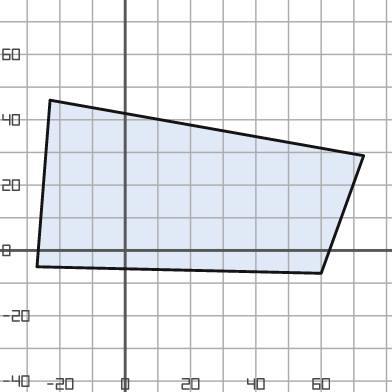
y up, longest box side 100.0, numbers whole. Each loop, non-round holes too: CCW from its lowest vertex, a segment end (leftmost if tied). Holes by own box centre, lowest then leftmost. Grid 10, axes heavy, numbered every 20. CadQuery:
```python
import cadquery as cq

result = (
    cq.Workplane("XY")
    .moveTo(60.0, -7.0)
    .lineTo(73.0, 29.0)
    .lineTo(-23.0, 46.0)
    .lineTo(-27.0, -5.0)
    .close()
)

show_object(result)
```